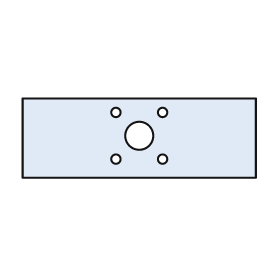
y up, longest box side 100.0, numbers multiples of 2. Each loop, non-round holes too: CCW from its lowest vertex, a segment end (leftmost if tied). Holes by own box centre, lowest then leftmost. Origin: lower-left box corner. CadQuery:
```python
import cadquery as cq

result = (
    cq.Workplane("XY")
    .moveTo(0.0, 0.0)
    .lineTo(100.0, 0.0)
    .lineTo(100.0, 34.0)
    .lineTo(0.0, 34.0)
    .close()
    .moveTo(40.0, 8.0)
    .circle(2.0)
    .moveTo(60.0, 8.0)
    .circle(2.0)
    .moveTo(50.0, 18.0)
    .circle(6.0)
    .moveTo(40.0, 28.0)
    .circle(2.0)
    .moveTo(60.0, 28.0)
    .circle(2.0)
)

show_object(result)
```